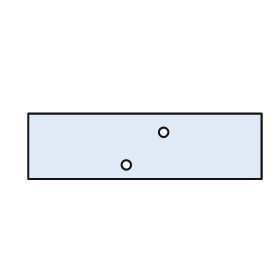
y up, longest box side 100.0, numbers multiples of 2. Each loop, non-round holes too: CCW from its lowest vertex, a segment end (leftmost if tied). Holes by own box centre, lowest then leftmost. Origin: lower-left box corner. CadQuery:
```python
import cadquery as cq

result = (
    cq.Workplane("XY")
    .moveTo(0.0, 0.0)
    .lineTo(100.0, 0.0)
    .lineTo(100.0, 28.0)
    .lineTo(0.0, 28.0)
    .close()
    .moveTo(42.0, 6.0)
    .circle(2.0)
    .moveTo(58.0, 20.0)
    .circle(2.0)
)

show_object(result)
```